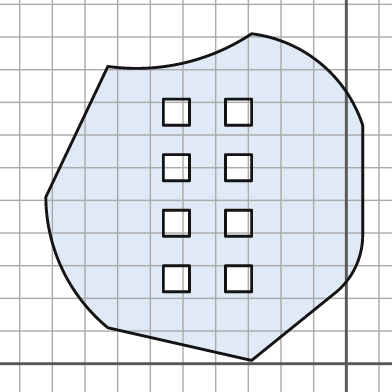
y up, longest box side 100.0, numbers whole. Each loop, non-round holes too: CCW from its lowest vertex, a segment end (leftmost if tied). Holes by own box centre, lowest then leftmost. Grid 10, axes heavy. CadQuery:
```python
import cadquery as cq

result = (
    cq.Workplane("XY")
    .moveTo(-29.0, 1.0)
    .lineTo(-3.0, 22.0)
    .threePointArc((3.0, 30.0), (5.0, 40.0))
    .lineTo(5.0, 73.0)
    .threePointArc((-8.0, 92.0), (-29.0, 101.0))
    .threePointArc((-50.0, 92.0), (-73.0, 91.0))
    .lineTo(-92.0, 51.0)
    .threePointArc((-87.0, 29.0), (-73.0, 11.0))
    .close()
    .moveTo(-56.0, 22.0)
    .lineTo(-48.0, 22.0)
    .lineTo(-48.0, 30.0)
    .lineTo(-56.0, 30.0)
    .close()
    .moveTo(-37.0, 22.0)
    .lineTo(-29.0, 22.0)
    .lineTo(-29.0, 30.0)
    .lineTo(-37.0, 30.0)
    .close()
    .moveTo(-56.0, 39.0)
    .lineTo(-48.0, 39.0)
    .lineTo(-48.0, 47.0)
    .lineTo(-56.0, 47.0)
    .close()
    .moveTo(-37.0, 39.0)
    .lineTo(-29.0, 39.0)
    .lineTo(-29.0, 47.0)
    .lineTo(-37.0, 47.0)
    .close()
    .moveTo(-56.0, 56.0)
    .lineTo(-48.0, 56.0)
    .lineTo(-48.0, 64.0)
    .lineTo(-56.0, 64.0)
    .close()
    .moveTo(-37.0, 56.0)
    .lineTo(-29.0, 56.0)
    .lineTo(-29.0, 64.0)
    .lineTo(-37.0, 64.0)
    .close()
    .moveTo(-56.0, 73.0)
    .lineTo(-48.0, 73.0)
    .lineTo(-48.0, 81.0)
    .lineTo(-56.0, 81.0)
    .close()
    .moveTo(-37.0, 73.0)
    .lineTo(-29.0, 73.0)
    .lineTo(-29.0, 81.0)
    .lineTo(-37.0, 81.0)
    .close()
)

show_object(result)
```